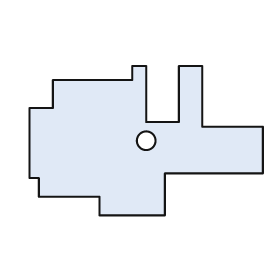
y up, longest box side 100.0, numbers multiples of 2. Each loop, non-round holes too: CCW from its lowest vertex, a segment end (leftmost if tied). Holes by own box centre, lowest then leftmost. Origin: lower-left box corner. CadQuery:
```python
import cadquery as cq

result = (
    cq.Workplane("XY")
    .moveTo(30.0, 0.0)
    .lineTo(58.0, 0.0)
    .lineTo(58.0, 18.0)
    .lineTo(100.0, 18.0)
    .lineTo(100.0, 38.0)
    .lineTo(74.0, 38.0)
    .lineTo(74.0, 64.0)
    .lineTo(64.0, 64.0)
    .lineTo(64.0, 40.0)
    .lineTo(50.0, 40.0)
    .lineTo(50.0, 64.0)
    .lineTo(44.0, 64.0)
    .lineTo(44.0, 58.0)
    .lineTo(10.0, 58.0)
    .lineTo(10.0, 46.0)
    .lineTo(0.0, 46.0)
    .lineTo(0.0, 16.0)
    .lineTo(4.0, 16.0)
    .lineTo(4.0, 8.0)
    .lineTo(30.0, 8.0)
    .close()
    .moveTo(50.0, 32.0)
    .circle(4.0)
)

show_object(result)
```